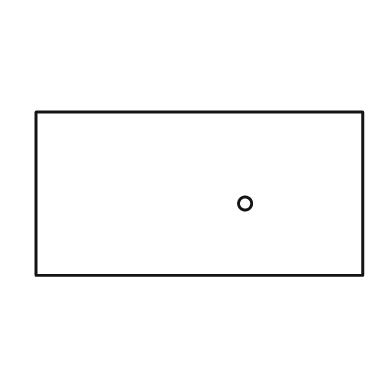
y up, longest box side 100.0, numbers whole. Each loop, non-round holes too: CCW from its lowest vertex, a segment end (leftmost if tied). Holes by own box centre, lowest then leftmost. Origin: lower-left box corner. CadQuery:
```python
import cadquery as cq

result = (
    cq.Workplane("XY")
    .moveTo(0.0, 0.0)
    .lineTo(100.0, 0.0)
    .lineTo(100.0, 50.0)
    .lineTo(0.0, 50.0)
    .close()
    .moveTo(64.0, 22.0)
    .circle(2.0)
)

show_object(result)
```